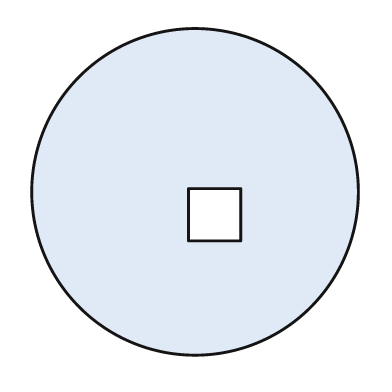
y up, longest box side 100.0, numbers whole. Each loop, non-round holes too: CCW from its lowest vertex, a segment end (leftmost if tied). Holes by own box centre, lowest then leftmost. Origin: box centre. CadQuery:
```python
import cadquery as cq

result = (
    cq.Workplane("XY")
    .moveTo(0.0, 0.0)
    .circle(50.0)
    .moveTo(-2.0, -15.0)
    .lineTo(14.0, -15.0)
    .lineTo(14.0, 1.0)
    .lineTo(-2.0, 1.0)
    .close()
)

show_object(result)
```